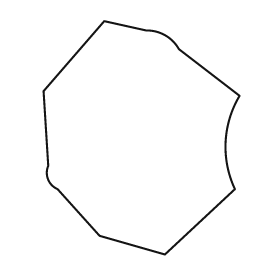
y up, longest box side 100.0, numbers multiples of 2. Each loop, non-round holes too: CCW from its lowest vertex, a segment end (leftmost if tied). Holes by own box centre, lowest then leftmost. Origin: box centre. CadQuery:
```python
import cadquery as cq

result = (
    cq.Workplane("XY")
    .moveTo(10.0, -50.0)
    .lineTo(40.0, -22.0)
    .threePointArc((36.0, -2.0), (42.0, 18.0))
    .lineTo(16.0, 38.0)
    .threePointArc((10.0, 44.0), (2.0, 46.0))
    .lineTo(-16.0, 50.0)
    .lineTo(-42.0, 20.0)
    .lineTo(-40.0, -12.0)
    .threePointArc((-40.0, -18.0), (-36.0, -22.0))
    .lineTo(-18.0, -42.0)
    .close()
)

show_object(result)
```